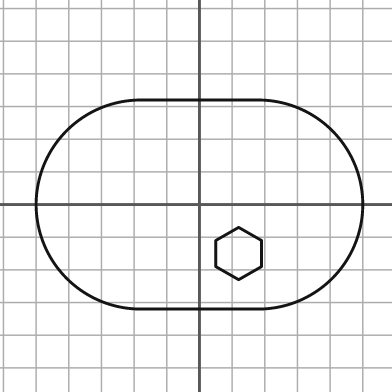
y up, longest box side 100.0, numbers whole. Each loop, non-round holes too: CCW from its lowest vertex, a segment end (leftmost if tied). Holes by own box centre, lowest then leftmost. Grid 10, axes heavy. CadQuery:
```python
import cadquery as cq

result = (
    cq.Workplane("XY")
    .moveTo(-18.0, -32.0)
    .lineTo(18.0, -32.0)
    .threePointArc((50.0, 0.0), (18.0, 32.0))
    .lineTo(-18.0, 32.0)
    .threePointArc((-50.0, 0.0), (-18.0, -32.0))
    .close()
    .moveTo(12.0, -23.0)
    .lineTo(19.0, -19.0)
    .lineTo(19.0, -11.0)
    .lineTo(12.0, -7.0)
    .lineTo(5.0, -11.0)
    .lineTo(5.0, -19.0)
    .close()
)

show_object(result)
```